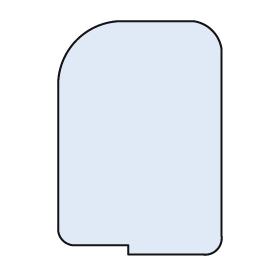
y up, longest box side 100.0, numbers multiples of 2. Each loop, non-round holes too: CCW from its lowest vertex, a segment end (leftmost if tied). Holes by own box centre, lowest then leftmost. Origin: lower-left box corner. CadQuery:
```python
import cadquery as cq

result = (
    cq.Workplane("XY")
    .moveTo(30.0, 0.0)
    .lineTo(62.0, 0.0)
    .threePointArc((68.0, 2.0), (70.0, 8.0))
    .lineTo(70.0, 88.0)
    .threePointArc((66.0, 96.0), (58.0, 100.0))
    .lineTo(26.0, 100.0)
    .threePointArc((8.0, 92.0), (0.0, 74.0))
    .lineTo(0.0, 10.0)
    .threePointArc((2.0, 6.0), (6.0, 4.0))
    .lineTo(30.0, 4.0)
    .close()
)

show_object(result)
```